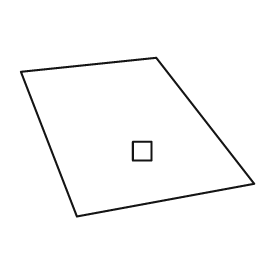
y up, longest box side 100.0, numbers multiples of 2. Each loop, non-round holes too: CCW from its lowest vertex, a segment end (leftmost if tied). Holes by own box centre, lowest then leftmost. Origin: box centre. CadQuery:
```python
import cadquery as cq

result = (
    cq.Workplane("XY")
    .moveTo(-26.0, -34.0)
    .lineTo(50.0, -20.0)
    .lineTo(8.0, 34.0)
    .lineTo(-50.0, 28.0)
    .close()
    .moveTo(-2.0, -10.0)
    .lineTo(6.0, -10.0)
    .lineTo(6.0, -2.0)
    .lineTo(-2.0, -2.0)
    .close()
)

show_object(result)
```